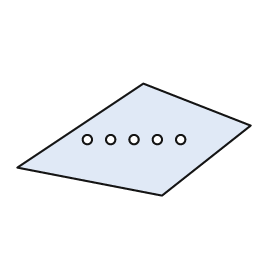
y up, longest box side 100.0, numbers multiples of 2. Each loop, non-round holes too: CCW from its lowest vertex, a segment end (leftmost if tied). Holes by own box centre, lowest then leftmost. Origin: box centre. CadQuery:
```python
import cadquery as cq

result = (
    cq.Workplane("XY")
    .moveTo(12.0, -24.0)
    .lineTo(50.0, 6.0)
    .lineTo(4.0, 24.0)
    .lineTo(-50.0, -12.0)
    .close()
    .moveTo(-20.0, 0.0)
    .circle(2.0)
    .moveTo(-10.0, 0.0)
    .circle(2.0)
    .moveTo(0.0, 0.0)
    .circle(2.0)
    .moveTo(10.0, 0.0)
    .circle(2.0)
    .moveTo(20.0, 0.0)
    .circle(2.0)
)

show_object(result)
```